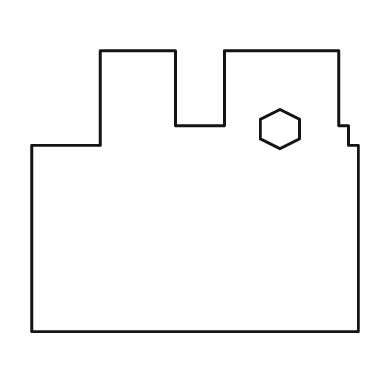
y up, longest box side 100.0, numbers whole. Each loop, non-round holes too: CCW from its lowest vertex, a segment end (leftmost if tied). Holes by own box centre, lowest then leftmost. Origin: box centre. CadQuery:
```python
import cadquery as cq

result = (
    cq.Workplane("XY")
    .moveTo(-50.0, -43.0)
    .lineTo(50.0, -43.0)
    .lineTo(50.0, 14.0)
    .lineTo(47.0, 14.0)
    .lineTo(47.0, 20.0)
    .lineTo(44.0, 20.0)
    .lineTo(44.0, 43.0)
    .lineTo(9.0, 43.0)
    .lineTo(9.0, 20.0)
    .lineTo(-6.0, 20.0)
    .lineTo(-6.0, 43.0)
    .lineTo(-29.0, 43.0)
    .lineTo(-29.0, 14.0)
    .lineTo(-50.0, 14.0)
    .close()
    .moveTo(26.0, 13.0)
    .lineTo(32.0, 16.0)
    .lineTo(32.0, 22.0)
    .lineTo(26.0, 25.0)
    .lineTo(20.0, 22.0)
    .lineTo(20.0, 16.0)
    .close()
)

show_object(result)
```